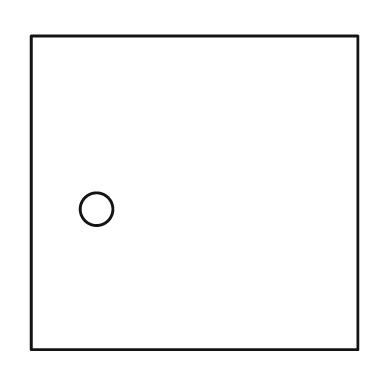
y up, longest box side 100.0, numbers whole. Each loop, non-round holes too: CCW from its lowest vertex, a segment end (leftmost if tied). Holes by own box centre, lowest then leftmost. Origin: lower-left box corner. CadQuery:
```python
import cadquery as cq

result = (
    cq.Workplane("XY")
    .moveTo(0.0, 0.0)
    .lineTo(100.0, 0.0)
    .lineTo(100.0, 96.0)
    .lineTo(0.0, 96.0)
    .close()
    .moveTo(20.0, 43.0)
    .circle(5.0)
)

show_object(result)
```